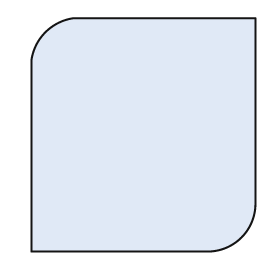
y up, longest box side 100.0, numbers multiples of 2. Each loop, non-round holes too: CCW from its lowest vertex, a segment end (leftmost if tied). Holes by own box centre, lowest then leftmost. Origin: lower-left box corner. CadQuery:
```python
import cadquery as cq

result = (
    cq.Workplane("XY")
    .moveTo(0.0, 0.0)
    .lineTo(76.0, 0.0)
    .threePointArc((90.0, 6.0), (96.0, 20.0))
    .lineTo(96.0, 100.0)
    .lineTo(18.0, 100.0)
    .threePointArc((6.0, 94.0), (0.0, 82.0))
    .close()
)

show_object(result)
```